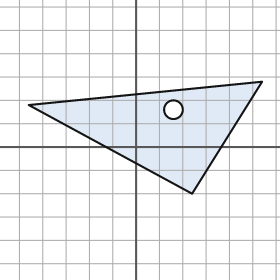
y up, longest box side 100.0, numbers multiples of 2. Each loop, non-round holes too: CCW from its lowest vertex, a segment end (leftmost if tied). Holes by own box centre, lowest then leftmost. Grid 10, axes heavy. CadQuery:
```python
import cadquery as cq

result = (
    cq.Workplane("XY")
    .moveTo(24.0, -20.0)
    .lineTo(54.0, 28.0)
    .lineTo(-46.0, 18.0)
    .close()
    .moveTo(16.0, 16.0)
    .circle(4.0)
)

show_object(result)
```